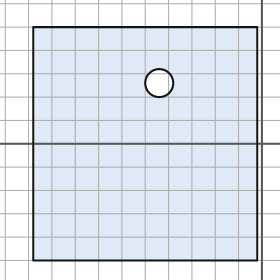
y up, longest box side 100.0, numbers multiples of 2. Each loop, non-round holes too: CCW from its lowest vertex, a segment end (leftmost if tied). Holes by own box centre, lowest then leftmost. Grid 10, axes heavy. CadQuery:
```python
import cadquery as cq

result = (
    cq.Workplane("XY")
    .moveTo(-98.0, -50.0)
    .lineTo(-2.0, -50.0)
    .lineTo(-2.0, 50.0)
    .lineTo(-98.0, 50.0)
    .close()
    .moveTo(-44.0, 26.0)
    .circle(6.0)
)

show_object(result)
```